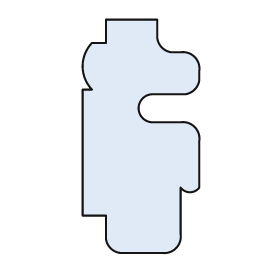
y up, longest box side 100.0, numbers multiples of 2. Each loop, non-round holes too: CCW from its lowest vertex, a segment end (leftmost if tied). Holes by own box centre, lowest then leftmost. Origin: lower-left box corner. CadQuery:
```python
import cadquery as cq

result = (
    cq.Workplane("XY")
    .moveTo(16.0, 0.0)
    .lineTo(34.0, 0.0)
    .threePointArc((40.0, 2.0), (42.0, 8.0))
    .lineTo(42.0, 28.0)
    .threePointArc((46.0, 26.0), (50.0, 28.0))
    .lineTo(50.0, 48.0)
    .threePointArc((48.0, 54.0), (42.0, 56.0))
    .lineTo(30.0, 56.0)
    .threePointArc((24.0, 62.0), (30.0, 68.0))
    .lineTo(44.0, 68.0)
    .threePointArc((48.0, 70.0), (50.0, 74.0))
    .lineTo(50.0, 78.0)
    .threePointArc((48.0, 84.0), (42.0, 86.0))
    .lineTo(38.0, 86.0)
    .threePointArc((34.0, 88.0), (32.0, 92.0))
    .lineTo(32.0, 100.0)
    .lineTo(10.0, 100.0)
    .lineTo(10.0, 90.0)
    .lineTo(4.0, 90.0)
    .threePointArc((0.0, 80.0), (4.0, 70.0))
    .lineTo(0.0, 70.0)
    .lineTo(0.0, 16.0)
    .lineTo(10.0, 16.0)
    .lineTo(10.0, 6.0)
    .threePointArc((12.0, 2.0), (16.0, 0.0))
    .close()
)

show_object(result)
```